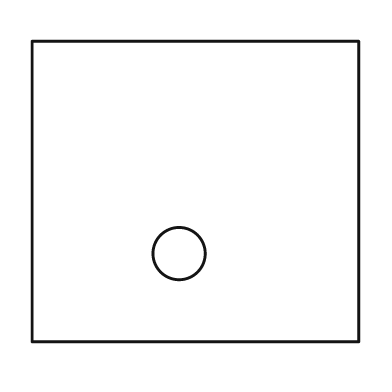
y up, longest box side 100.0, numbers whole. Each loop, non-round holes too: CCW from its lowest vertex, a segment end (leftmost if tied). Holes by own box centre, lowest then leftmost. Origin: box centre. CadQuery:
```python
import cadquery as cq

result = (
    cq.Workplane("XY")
    .moveTo(-50.0, -46.0)
    .lineTo(50.0, -46.0)
    .lineTo(50.0, 46.0)
    .lineTo(-50.0, 46.0)
    .close()
    .moveTo(-5.0, -19.0)
    .circle(8.0)
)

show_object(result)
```